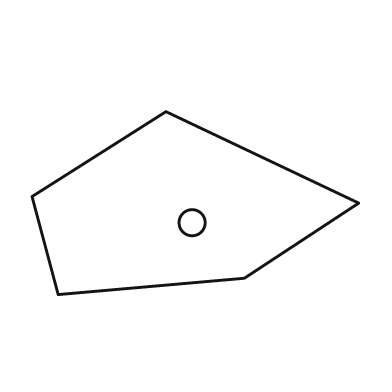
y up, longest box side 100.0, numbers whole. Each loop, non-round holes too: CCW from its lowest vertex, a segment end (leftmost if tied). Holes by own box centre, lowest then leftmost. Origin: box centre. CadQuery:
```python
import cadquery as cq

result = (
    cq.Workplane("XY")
    .moveTo(-42.0, -28.0)
    .lineTo(15.0, -23.0)
    .lineTo(50.0, 0.0)
    .lineTo(-9.0, 28.0)
    .lineTo(-50.0, 2.0)
    .close()
    .moveTo(-1.0, -6.0)
    .circle(4.0)
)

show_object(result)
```